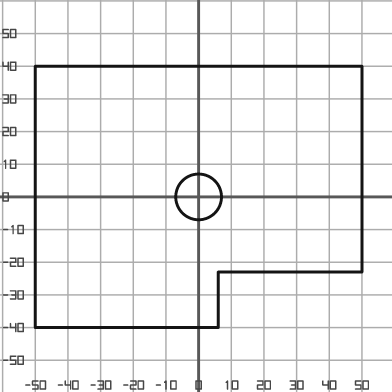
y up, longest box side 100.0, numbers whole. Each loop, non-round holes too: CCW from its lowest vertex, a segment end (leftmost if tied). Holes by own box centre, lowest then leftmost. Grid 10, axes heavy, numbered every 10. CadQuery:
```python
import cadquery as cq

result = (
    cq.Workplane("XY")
    .moveTo(-50.0, -40.0)
    .lineTo(6.0, -40.0)
    .lineTo(6.0, -23.0)
    .lineTo(50.0, -23.0)
    .lineTo(50.0, 40.0)
    .lineTo(-50.0, 40.0)
    .close()
    .moveTo(0.0, 0.0)
    .circle(7.0)
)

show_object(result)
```